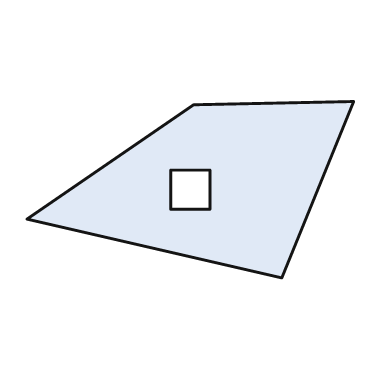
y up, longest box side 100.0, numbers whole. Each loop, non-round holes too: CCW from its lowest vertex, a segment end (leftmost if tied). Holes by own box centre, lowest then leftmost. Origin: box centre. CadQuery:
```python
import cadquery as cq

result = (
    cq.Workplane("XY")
    .moveTo(28.0, -27.0)
    .lineTo(50.0, 27.0)
    .lineTo(1.0, 26.0)
    .lineTo(-50.0, -9.0)
    .close()
    .moveTo(-6.0, -6.0)
    .lineTo(6.0, -6.0)
    .lineTo(6.0, 6.0)
    .lineTo(-6.0, 6.0)
    .close()
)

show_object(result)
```